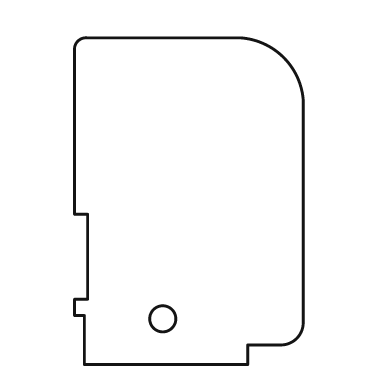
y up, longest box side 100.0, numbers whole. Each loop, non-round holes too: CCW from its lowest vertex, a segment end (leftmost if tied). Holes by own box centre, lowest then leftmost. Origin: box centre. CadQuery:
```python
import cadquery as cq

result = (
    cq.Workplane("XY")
    .moveTo(-32.0, -50.0)
    .lineTo(18.0, -50.0)
    .lineTo(18.0, -44.0)
    .lineTo(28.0, -44.0)
    .threePointArc((33.0, -42.0), (35.0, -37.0))
    .lineTo(35.0, 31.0)
    .threePointArc((29.0, 44.0), (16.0, 50.0))
    .lineTo(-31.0, 50.0)
    .threePointArc((-34.0, 49.0), (-35.0, 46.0))
    .lineTo(-35.0, -4.0)
    .lineTo(-31.0, -4.0)
    .lineTo(-31.0, -30.0)
    .lineTo(-35.0, -30.0)
    .lineTo(-35.0, -35.0)
    .lineTo(-32.0, -35.0)
    .close()
    .moveTo(-8.0, -36.0)
    .circle(4.0)
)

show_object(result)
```